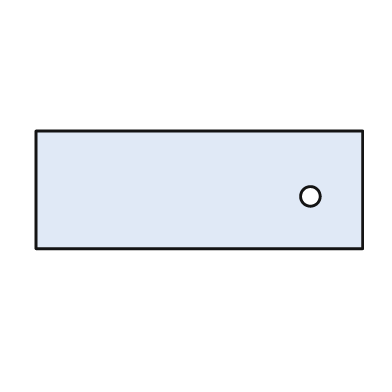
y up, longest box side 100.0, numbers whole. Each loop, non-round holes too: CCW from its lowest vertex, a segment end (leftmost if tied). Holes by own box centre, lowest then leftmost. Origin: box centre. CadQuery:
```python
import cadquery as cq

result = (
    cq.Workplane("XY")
    .moveTo(-50.0, -18.0)
    .lineTo(50.0, -18.0)
    .lineTo(50.0, 18.0)
    .lineTo(-50.0, 18.0)
    .close()
    .moveTo(34.0, -2.0)
    .circle(3.0)
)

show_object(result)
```